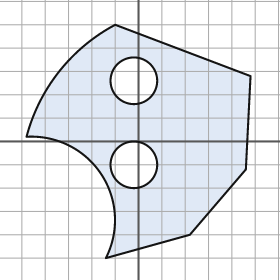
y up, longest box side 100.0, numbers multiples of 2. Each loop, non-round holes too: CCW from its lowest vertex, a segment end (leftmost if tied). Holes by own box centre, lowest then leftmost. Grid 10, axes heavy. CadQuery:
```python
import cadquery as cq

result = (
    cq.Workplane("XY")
    .moveTo(-14.0, -50.0)
    .lineTo(22.0, -40.0)
    .lineTo(46.0, -12.0)
    .lineTo(48.0, 28.0)
    .lineTo(-10.0, 50.0)
    .threePointArc((-34.0, 30.0), (-48.0, 2.0))
    .threePointArc((-16.0, -14.0), (-14.0, -50.0))
    .close()
    .moveTo(-2.0, -10.0)
    .circle(10.0)
    .moveTo(-2.0, 26.0)
    .circle(10.0)
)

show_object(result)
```